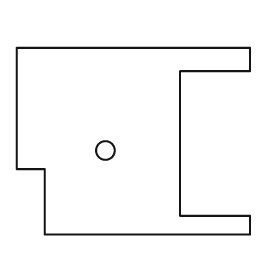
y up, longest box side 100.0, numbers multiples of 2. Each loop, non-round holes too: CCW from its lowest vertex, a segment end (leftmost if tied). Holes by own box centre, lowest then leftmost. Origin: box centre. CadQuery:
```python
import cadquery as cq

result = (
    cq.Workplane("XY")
    .moveTo(-38.0, -40.0)
    .lineTo(50.0, -40.0)
    .lineTo(50.0, -32.0)
    .lineTo(20.0, -32.0)
    .lineTo(20.0, 30.0)
    .lineTo(50.0, 30.0)
    .lineTo(50.0, 40.0)
    .lineTo(-50.0, 40.0)
    .lineTo(-50.0, -12.0)
    .lineTo(-38.0, -12.0)
    .close()
    .moveTo(-12.0, -4.0)
    .circle(4.0)
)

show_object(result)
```